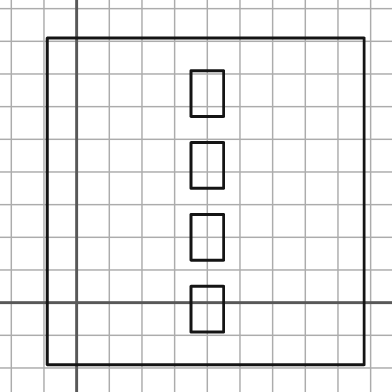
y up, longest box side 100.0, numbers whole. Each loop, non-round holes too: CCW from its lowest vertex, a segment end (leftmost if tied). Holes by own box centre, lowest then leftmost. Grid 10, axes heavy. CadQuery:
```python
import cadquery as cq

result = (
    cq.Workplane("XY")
    .moveTo(-9.0, -19.0)
    .lineTo(88.0, -19.0)
    .lineTo(88.0, 81.0)
    .lineTo(-9.0, 81.0)
    .close()
    .moveTo(35.0, -9.0)
    .lineTo(45.0, -9.0)
    .lineTo(45.0, 5.0)
    .lineTo(35.0, 5.0)
    .close()
    .moveTo(35.0, 13.0)
    .lineTo(45.0, 13.0)
    .lineTo(45.0, 27.0)
    .lineTo(35.0, 27.0)
    .close()
    .moveTo(35.0, 35.0)
    .lineTo(45.0, 35.0)
    .lineTo(45.0, 49.0)
    .lineTo(35.0, 49.0)
    .close()
    .moveTo(35.0, 57.0)
    .lineTo(45.0, 57.0)
    .lineTo(45.0, 71.0)
    .lineTo(35.0, 71.0)
    .close()
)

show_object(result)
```